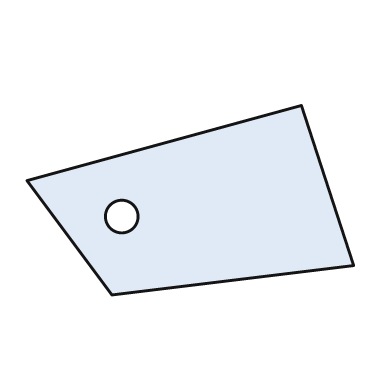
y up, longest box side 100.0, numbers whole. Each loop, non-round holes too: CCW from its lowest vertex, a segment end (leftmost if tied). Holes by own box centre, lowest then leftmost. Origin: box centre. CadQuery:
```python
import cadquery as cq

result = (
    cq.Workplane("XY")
    .moveTo(-24.0, -29.0)
    .lineTo(50.0, -20.0)
    .lineTo(34.0, 29.0)
    .lineTo(-50.0, 6.0)
    .close()
    .moveTo(-21.0, -5.0)
    .circle(5.0)
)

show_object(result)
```